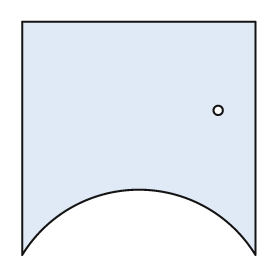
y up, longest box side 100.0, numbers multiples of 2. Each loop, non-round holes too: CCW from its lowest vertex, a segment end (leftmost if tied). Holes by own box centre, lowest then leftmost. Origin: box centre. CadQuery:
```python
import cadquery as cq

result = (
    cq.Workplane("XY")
    .moveTo(-50.0, -50.0)
    .threePointArc((0.0, -22.0), (50.0, -50.0))
    .lineTo(50.0, 50.0)
    .lineTo(-50.0, 50.0)
    .close()
    .moveTo(34.0, 12.0)
    .circle(2.0)
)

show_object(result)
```